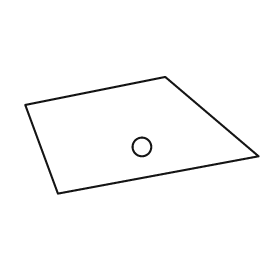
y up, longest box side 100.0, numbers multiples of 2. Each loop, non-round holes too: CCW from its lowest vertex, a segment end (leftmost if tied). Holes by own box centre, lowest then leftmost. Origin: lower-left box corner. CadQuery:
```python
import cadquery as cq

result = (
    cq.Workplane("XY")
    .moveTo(14.0, 0.0)
    .lineTo(100.0, 16.0)
    .lineTo(60.0, 50.0)
    .lineTo(0.0, 38.0)
    .close()
    .moveTo(50.0, 20.0)
    .circle(4.0)
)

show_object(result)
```